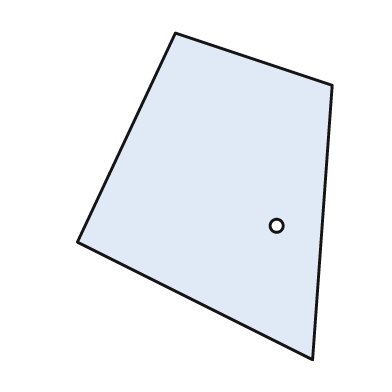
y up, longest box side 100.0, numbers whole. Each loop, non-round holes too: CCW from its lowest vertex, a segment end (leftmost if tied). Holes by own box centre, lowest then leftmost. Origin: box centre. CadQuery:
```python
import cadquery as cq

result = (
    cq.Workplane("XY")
    .moveTo(33.0, -50.0)
    .lineTo(39.0, 34.0)
    .lineTo(-9.0, 50.0)
    .lineTo(-39.0, -14.0)
    .close()
    .moveTo(22.0, -9.0)
    .circle(2.0)
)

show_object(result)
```